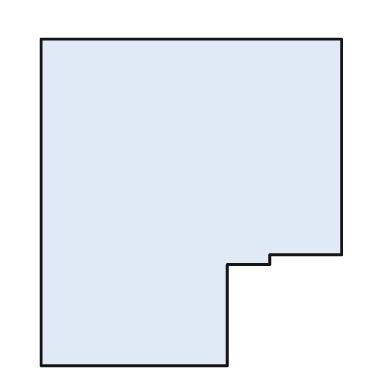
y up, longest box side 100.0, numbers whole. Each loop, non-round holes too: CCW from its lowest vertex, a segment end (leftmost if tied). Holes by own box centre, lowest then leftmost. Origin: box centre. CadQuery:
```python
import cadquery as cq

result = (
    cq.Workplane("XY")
    .moveTo(-46.0, -50.0)
    .lineTo(11.0, -50.0)
    .lineTo(11.0, -19.0)
    .lineTo(24.0, -19.0)
    .lineTo(24.0, -16.0)
    .lineTo(46.0, -16.0)
    .lineTo(46.0, 50.0)
    .lineTo(-46.0, 50.0)
    .close()
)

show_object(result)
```